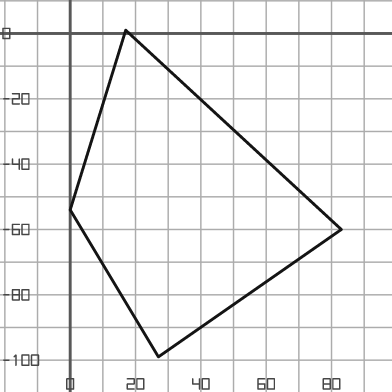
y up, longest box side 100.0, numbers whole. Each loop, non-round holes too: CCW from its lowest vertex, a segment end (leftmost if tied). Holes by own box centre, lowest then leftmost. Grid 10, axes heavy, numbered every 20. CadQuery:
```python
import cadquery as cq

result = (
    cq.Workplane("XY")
    .moveTo(27.0, -99.0)
    .lineTo(83.0, -60.0)
    .lineTo(17.0, 1.0)
    .lineTo(0.0, -54.0)
    .close()
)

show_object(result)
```